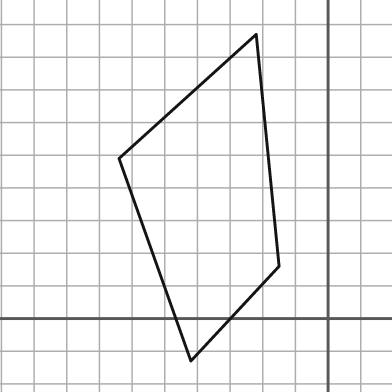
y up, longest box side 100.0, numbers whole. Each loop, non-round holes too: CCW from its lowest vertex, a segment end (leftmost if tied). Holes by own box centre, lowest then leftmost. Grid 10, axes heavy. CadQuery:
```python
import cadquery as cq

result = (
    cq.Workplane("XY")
    .moveTo(-42.0, -13.0)
    .lineTo(-15.0, 16.0)
    .lineTo(-22.0, 87.0)
    .lineTo(-64.0, 49.0)
    .close()
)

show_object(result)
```